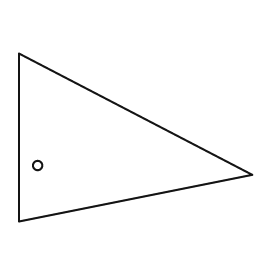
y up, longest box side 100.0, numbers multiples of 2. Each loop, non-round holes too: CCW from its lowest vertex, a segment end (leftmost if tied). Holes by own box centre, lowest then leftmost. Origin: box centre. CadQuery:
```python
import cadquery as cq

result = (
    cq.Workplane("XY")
    .moveTo(-50.0, -36.0)
    .lineTo(50.0, -16.0)
    .lineTo(-50.0, 36.0)
    .close()
    .moveTo(-42.0, -12.0)
    .circle(2.0)
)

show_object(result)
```